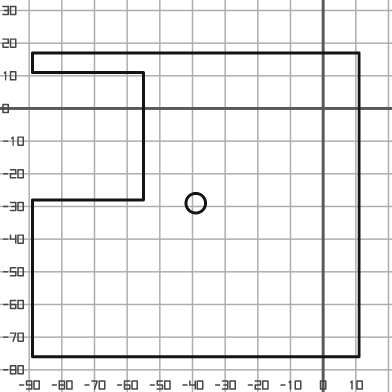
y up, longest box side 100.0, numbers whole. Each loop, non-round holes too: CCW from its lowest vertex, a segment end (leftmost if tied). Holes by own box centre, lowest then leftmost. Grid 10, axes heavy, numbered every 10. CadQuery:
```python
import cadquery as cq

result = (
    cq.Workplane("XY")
    .moveTo(-89.0, -76.0)
    .lineTo(11.0, -76.0)
    .lineTo(11.0, 17.0)
    .lineTo(-89.0, 17.0)
    .lineTo(-89.0, 11.0)
    .lineTo(-55.0, 11.0)
    .lineTo(-55.0, -28.0)
    .lineTo(-89.0, -28.0)
    .close()
    .moveTo(-39.0, -29.0)
    .circle(3.0)
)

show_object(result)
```